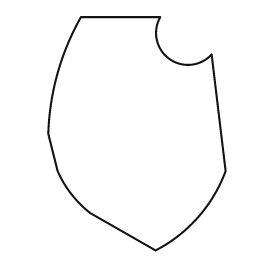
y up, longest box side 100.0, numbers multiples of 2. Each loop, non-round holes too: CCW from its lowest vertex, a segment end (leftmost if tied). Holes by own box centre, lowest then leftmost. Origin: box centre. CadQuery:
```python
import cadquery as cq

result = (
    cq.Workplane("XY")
    .moveTo(8.0, -50.0)
    .threePointArc((26.0, -36.0), (38.0, -16.0))
    .lineTo(32.0, 34.0)
    .threePointArc((14.0, 32.0), (10.0, 50.0))
    .lineTo(-24.0, 50.0)
    .threePointArc((-34.0, 26.0), (-38.0, 0.0))
    .lineTo(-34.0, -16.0)
    .threePointArc((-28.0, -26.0), (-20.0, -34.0))
    .close()
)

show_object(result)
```